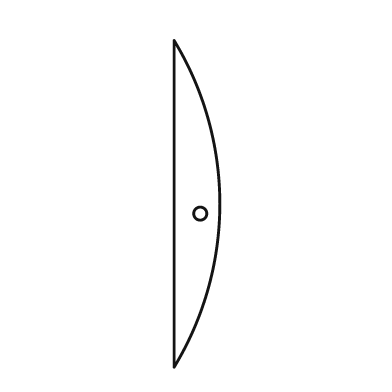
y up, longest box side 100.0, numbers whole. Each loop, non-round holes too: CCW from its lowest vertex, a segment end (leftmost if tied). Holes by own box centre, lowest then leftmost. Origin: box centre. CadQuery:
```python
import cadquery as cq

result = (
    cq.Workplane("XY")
    .moveTo(-7.0, -50.0)
    .threePointArc((7.0, 0.0), (-7.0, 50.0))
    .close()
    .moveTo(1.0, -3.0)
    .circle(2.0)
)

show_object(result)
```